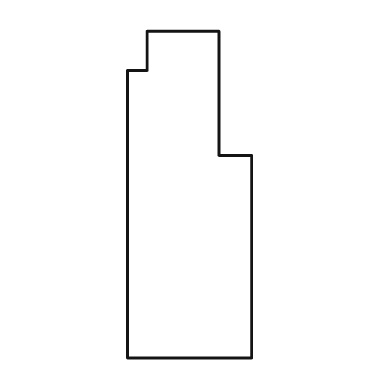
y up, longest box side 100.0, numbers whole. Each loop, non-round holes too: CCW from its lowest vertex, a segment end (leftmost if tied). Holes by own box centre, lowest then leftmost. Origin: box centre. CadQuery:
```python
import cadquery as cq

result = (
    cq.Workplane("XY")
    .moveTo(-19.0, -50.0)
    .lineTo(19.0, -50.0)
    .lineTo(19.0, 12.0)
    .lineTo(9.0, 12.0)
    .lineTo(9.0, 50.0)
    .lineTo(-13.0, 50.0)
    .lineTo(-13.0, 38.0)
    .lineTo(-19.0, 38.0)
    .close()
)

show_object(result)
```